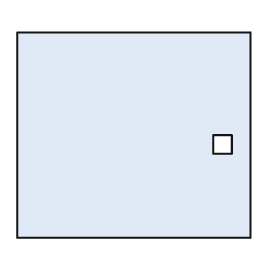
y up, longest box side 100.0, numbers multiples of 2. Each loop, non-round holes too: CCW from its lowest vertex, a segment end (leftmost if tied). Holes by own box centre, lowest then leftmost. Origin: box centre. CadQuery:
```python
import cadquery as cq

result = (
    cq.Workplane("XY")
    .moveTo(-50.0, -44.0)
    .lineTo(50.0, -44.0)
    .lineTo(50.0, 44.0)
    .lineTo(-50.0, 44.0)
    .close()
    .moveTo(34.0, -8.0)
    .lineTo(42.0, -8.0)
    .lineTo(42.0, 0.0)
    .lineTo(34.0, 0.0)
    .close()
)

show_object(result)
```